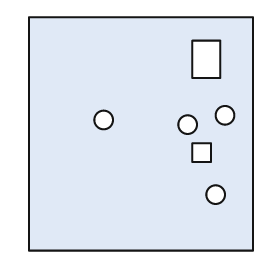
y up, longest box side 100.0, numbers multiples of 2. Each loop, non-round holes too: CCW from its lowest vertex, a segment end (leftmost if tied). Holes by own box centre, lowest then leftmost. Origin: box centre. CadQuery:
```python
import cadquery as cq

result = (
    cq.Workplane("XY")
    .moveTo(-48.0, -50.0)
    .lineTo(48.0, -50.0)
    .lineTo(48.0, 50.0)
    .lineTo(-48.0, 50.0)
    .close()
    .moveTo(32.0, -26.0)
    .circle(4.0)
    .moveTo(22.0, -12.0)
    .lineTo(30.0, -12.0)
    .lineTo(30.0, -4.0)
    .lineTo(22.0, -4.0)
    .close()
    .moveTo(20.0, 4.0)
    .circle(4.0)
    .moveTo(-16.0, 6.0)
    .circle(4.0)
    .moveTo(36.0, 8.0)
    .circle(4.0)
    .moveTo(22.0, 24.0)
    .lineTo(34.0, 24.0)
    .lineTo(34.0, 40.0)
    .lineTo(22.0, 40.0)
    .close()
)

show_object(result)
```